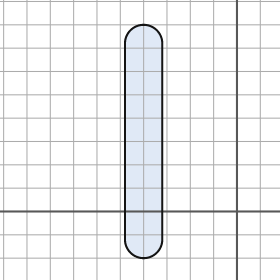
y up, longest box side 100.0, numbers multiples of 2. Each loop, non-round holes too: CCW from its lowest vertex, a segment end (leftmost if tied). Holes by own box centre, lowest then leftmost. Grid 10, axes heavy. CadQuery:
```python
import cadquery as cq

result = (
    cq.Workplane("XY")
    .moveTo(-48.0, -12.0)
    .threePointArc((-40.0, -20.0), (-32.0, -12.0))
    .lineTo(-32.0, 72.0)
    .threePointArc((-40.0, 80.0), (-48.0, 72.0))
    .close()
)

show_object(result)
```